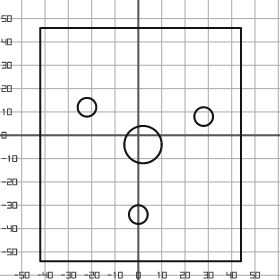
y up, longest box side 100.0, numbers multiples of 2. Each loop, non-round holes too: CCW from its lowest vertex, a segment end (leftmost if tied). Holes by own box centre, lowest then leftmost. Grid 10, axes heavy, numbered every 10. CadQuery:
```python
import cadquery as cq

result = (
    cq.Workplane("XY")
    .moveTo(-42.0, -54.0)
    .lineTo(44.0, -54.0)
    .lineTo(44.0, 46.0)
    .lineTo(-42.0, 46.0)
    .close()
    .moveTo(0.0, -34.0)
    .circle(4.0)
    .moveTo(2.0, -4.0)
    .circle(8.0)
    .moveTo(28.0, 8.0)
    .circle(4.0)
    .moveTo(-22.0, 12.0)
    .circle(4.0)
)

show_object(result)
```